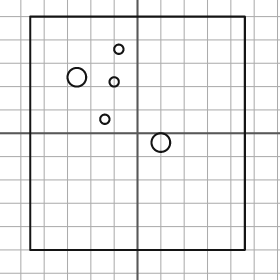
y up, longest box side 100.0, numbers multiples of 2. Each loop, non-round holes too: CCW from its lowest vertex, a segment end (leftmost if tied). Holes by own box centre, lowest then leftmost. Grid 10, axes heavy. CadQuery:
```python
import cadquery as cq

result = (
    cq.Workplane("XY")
    .moveTo(-46.0, -50.0)
    .lineTo(46.0, -50.0)
    .lineTo(46.0, 50.0)
    .lineTo(-46.0, 50.0)
    .close()
    .moveTo(10.0, -4.0)
    .circle(4.0)
    .moveTo(-14.0, 6.0)
    .circle(2.0)
    .moveTo(-10.0, 22.0)
    .circle(2.0)
    .moveTo(-26.0, 24.0)
    .circle(4.0)
    .moveTo(-8.0, 36.0)
    .circle(2.0)
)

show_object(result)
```